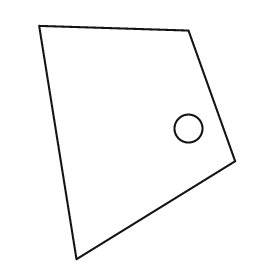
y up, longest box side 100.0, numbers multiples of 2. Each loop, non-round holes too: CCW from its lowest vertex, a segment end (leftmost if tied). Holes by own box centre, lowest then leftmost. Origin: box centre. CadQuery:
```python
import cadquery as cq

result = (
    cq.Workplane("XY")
    .moveTo(-26.0, -50.0)
    .lineTo(42.0, -8.0)
    .lineTo(22.0, 48.0)
    .lineTo(-42.0, 50.0)
    .close()
    .moveTo(22.0, 6.0)
    .circle(6.0)
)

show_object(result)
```